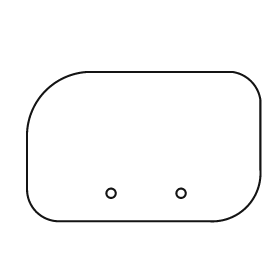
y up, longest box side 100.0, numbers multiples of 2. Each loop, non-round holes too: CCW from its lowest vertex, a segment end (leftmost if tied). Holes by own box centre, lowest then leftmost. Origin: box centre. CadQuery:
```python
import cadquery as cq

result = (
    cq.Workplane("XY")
    .moveTo(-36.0, -32.0)
    .lineTo(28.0, -32.0)
    .threePointArc((44.0, -26.0), (50.0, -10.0))
    .lineTo(50.0, 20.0)
    .threePointArc((46.0, 28.0), (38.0, 32.0))
    .lineTo(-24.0, 32.0)
    .threePointArc((-42.0, 24.0), (-50.0, 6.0))
    .lineTo(-50.0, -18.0)
    .threePointArc((-46.0, -28.0), (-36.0, -32.0))
    .close()
    .moveTo(-14.0, -20.0)
    .circle(2.0)
    .moveTo(16.0, -20.0)
    .circle(2.0)
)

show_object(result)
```